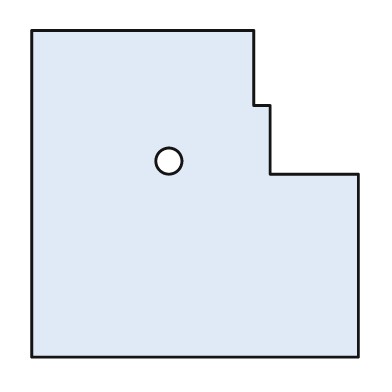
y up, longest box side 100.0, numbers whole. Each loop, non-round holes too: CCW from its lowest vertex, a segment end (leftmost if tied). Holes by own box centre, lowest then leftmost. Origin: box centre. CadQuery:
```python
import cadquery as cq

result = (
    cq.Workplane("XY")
    .moveTo(-50.0, -50.0)
    .lineTo(50.0, -50.0)
    .lineTo(50.0, 6.0)
    .lineTo(23.0, 6.0)
    .lineTo(23.0, 27.0)
    .lineTo(18.0, 27.0)
    .lineTo(18.0, 50.0)
    .lineTo(-50.0, 50.0)
    .close()
    .moveTo(-8.0, 10.0)
    .circle(4.0)
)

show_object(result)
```